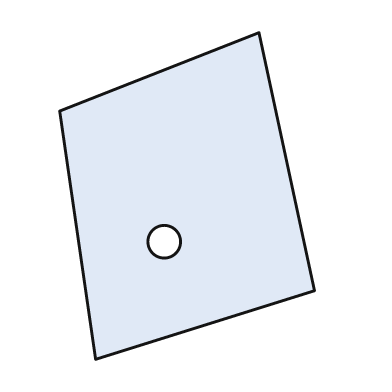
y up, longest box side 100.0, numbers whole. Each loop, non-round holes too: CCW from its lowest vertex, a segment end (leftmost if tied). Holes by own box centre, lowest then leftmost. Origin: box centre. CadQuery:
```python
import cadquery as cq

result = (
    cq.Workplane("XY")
    .moveTo(-28.0, -50.0)
    .lineTo(39.0, -29.0)
    .lineTo(22.0, 50.0)
    .lineTo(-39.0, 26.0)
    .close()
    .moveTo(-7.0, -14.0)
    .circle(5.0)
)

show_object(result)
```